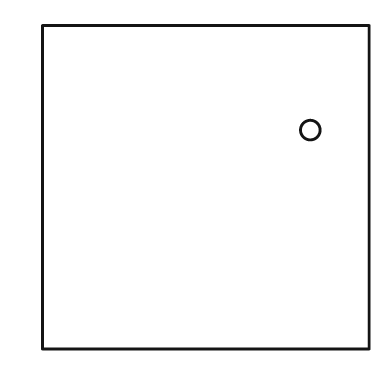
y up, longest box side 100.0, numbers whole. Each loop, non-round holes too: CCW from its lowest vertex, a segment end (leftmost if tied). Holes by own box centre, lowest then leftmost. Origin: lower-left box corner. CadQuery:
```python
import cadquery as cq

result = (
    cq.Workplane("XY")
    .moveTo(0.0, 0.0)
    .lineTo(100.0, 0.0)
    .lineTo(100.0, 99.0)
    .lineTo(0.0, 99.0)
    .close()
    .moveTo(82.0, 67.0)
    .circle(3.0)
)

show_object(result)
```